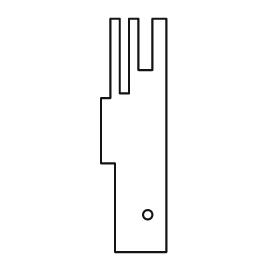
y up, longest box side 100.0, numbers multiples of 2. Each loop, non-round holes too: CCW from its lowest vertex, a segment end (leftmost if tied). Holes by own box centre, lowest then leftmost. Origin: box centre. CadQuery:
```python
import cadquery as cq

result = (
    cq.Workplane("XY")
    .moveTo(-8.0, -50.0)
    .lineTo(14.0, -50.0)
    .lineTo(14.0, 50.0)
    .lineTo(8.0, 50.0)
    .lineTo(8.0, 28.0)
    .lineTo(2.0, 28.0)
    .lineTo(2.0, 50.0)
    .lineTo(-2.0, 50.0)
    .lineTo(-2.0, 18.0)
    .lineTo(-6.0, 18.0)
    .lineTo(-6.0, 50.0)
    .lineTo(-10.0, 50.0)
    .lineTo(-10.0, 16.0)
    .lineTo(-14.0, 16.0)
    .lineTo(-14.0, -12.0)
    .lineTo(-8.0, -12.0)
    .close()
    .moveTo(6.0, -34.0)
    .circle(2.0)
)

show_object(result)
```